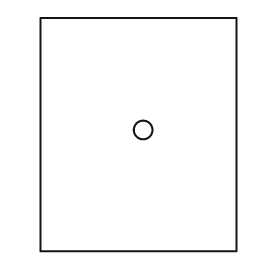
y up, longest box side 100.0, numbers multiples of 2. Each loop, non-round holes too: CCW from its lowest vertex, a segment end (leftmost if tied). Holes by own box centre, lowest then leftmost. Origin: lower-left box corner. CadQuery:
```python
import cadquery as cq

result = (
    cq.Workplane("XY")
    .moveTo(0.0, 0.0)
    .lineTo(84.0, 0.0)
    .lineTo(84.0, 100.0)
    .lineTo(0.0, 100.0)
    .close()
    .moveTo(44.0, 52.0)
    .circle(4.0)
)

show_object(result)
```